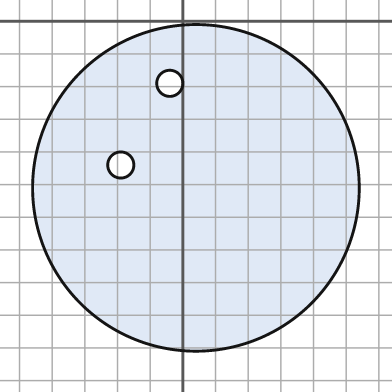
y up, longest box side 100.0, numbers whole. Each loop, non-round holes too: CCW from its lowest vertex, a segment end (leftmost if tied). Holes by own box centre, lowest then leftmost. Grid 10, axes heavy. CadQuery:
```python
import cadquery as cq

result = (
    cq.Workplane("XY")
    .moveTo(4.0, -51.0)
    .circle(50.0)
    .moveTo(-19.0, -44.0)
    .circle(4.0)
    .moveTo(-4.0, -19.0)
    .circle(4.0)
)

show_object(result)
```